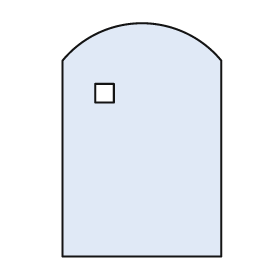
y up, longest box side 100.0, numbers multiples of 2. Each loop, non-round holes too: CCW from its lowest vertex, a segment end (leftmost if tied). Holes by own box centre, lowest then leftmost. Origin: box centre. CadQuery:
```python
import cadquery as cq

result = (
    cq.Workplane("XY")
    .moveTo(-34.0, -50.0)
    .lineTo(34.0, -50.0)
    .lineTo(34.0, 34.0)
    .threePointArc((0.0, 50.0), (-34.0, 34.0))
    .close()
    .moveTo(-20.0, 16.0)
    .lineTo(-12.0, 16.0)
    .lineTo(-12.0, 24.0)
    .lineTo(-20.0, 24.0)
    .close()
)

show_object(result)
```